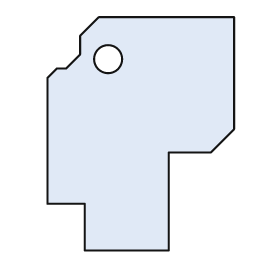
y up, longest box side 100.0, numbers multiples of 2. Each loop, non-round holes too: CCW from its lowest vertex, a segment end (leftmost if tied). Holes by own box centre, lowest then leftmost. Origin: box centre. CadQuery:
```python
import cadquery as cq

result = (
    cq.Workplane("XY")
    .moveTo(-24.0, -50.0)
    .lineTo(12.0, -50.0)
    .lineTo(12.0, -8.0)
    .lineTo(30.0, -8.0)
    .lineTo(40.0, 2.0)
    .lineTo(40.0, 50.0)
    .lineTo(-18.0, 50.0)
    .lineTo(-26.0, 42.0)
    .lineTo(-26.0, 34.0)
    .lineTo(-32.0, 28.0)
    .lineTo(-36.0, 28.0)
    .lineTo(-40.0, 24.0)
    .lineTo(-40.0, -30.0)
    .lineTo(-24.0, -30.0)
    .close()
    .moveTo(-14.0, 32.0)
    .circle(6.0)
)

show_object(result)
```